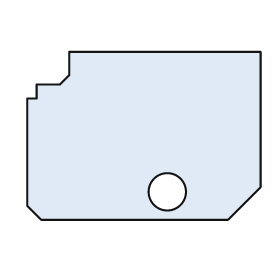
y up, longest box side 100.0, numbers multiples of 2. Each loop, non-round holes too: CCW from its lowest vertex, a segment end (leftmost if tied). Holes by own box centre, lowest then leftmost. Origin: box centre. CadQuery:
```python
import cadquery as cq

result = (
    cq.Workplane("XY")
    .moveTo(-44.0, -36.0)
    .lineTo(36.0, -36.0)
    .lineTo(50.0, -22.0)
    .lineTo(50.0, 36.0)
    .lineTo(-32.0, 36.0)
    .lineTo(-32.0, 26.0)
    .lineTo(-36.0, 22.0)
    .lineTo(-46.0, 22.0)
    .lineTo(-46.0, 16.0)
    .lineTo(-50.0, 16.0)
    .lineTo(-50.0, -30.0)
    .close()
    .moveTo(10.0, -24.0)
    .circle(8.0)
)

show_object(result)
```